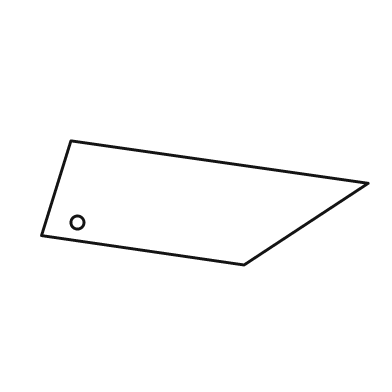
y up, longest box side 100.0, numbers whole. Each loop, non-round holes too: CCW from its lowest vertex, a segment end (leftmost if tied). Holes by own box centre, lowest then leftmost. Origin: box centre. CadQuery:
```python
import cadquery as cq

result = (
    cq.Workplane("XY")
    .moveTo(12.0, -19.0)
    .lineTo(50.0, 6.0)
    .lineTo(-41.0, 19.0)
    .lineTo(-50.0, -10.0)
    .close()
    .moveTo(-39.0, -6.0)
    .circle(2.0)
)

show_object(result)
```